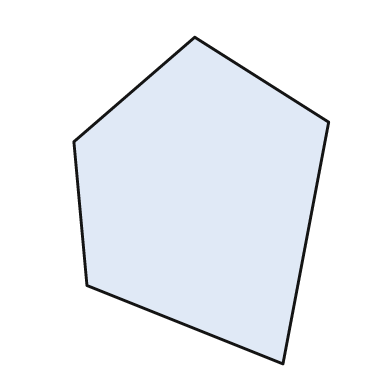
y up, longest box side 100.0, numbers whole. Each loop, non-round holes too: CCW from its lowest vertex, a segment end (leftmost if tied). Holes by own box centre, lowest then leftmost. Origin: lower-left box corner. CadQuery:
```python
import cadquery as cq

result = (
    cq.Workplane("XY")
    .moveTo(64.0, 0.0)
    .lineTo(78.0, 74.0)
    .lineTo(37.0, 100.0)
    .lineTo(0.0, 68.0)
    .lineTo(4.0, 24.0)
    .close()
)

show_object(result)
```